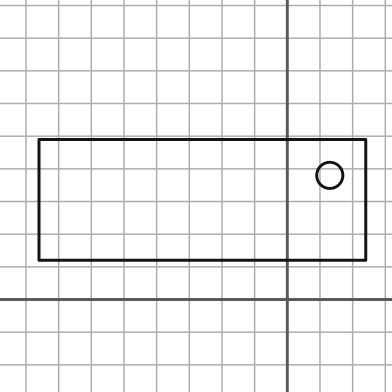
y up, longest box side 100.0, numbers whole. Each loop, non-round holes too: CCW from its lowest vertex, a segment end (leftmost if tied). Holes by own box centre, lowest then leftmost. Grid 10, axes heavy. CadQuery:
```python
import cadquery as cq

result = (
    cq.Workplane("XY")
    .moveTo(-76.0, 12.0)
    .lineTo(24.0, 12.0)
    .lineTo(24.0, 49.0)
    .lineTo(-76.0, 49.0)
    .close()
    .moveTo(13.0, 38.0)
    .circle(4.0)
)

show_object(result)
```